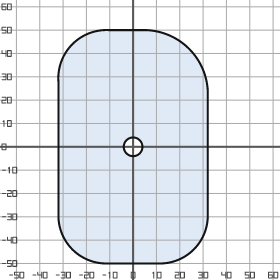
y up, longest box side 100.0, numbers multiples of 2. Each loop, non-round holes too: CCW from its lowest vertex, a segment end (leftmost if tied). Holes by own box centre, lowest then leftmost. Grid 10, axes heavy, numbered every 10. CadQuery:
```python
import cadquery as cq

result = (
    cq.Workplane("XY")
    .moveTo(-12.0, -50.0)
    .lineTo(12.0, -50.0)
    .threePointArc((26.0, -44.0), (32.0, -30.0))
    .lineTo(32.0, 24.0)
    .threePointArc((24.0, 42.0), (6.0, 50.0))
    .lineTo(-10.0, 50.0)
    .threePointArc((-26.0, 44.0), (-32.0, 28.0))
    .lineTo(-32.0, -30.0)
    .threePointArc((-26.0, -44.0), (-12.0, -50.0))
    .close()
    .moveTo(0.0, 0.0)
    .circle(4.0)
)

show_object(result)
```